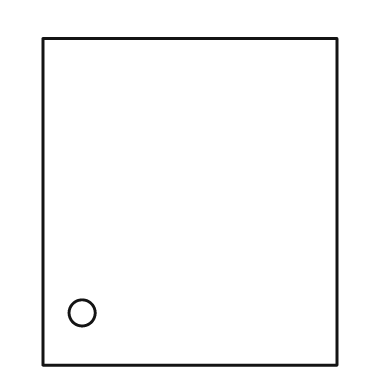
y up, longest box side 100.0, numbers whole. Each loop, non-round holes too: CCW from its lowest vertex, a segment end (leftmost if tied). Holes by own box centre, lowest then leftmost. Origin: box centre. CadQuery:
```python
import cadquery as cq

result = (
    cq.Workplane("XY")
    .moveTo(-45.0, -50.0)
    .lineTo(45.0, -50.0)
    .lineTo(45.0, 50.0)
    .lineTo(-45.0, 50.0)
    .close()
    .moveTo(-33.0, -34.0)
    .circle(4.0)
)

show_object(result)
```